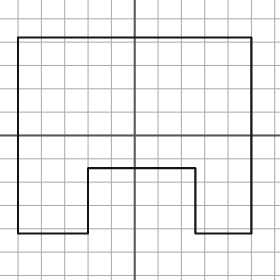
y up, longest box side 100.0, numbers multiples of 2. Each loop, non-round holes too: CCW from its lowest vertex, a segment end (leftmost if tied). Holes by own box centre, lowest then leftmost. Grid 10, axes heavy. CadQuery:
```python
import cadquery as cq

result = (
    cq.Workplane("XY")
    .moveTo(-50.0, -42.0)
    .lineTo(-20.0, -42.0)
    .lineTo(-20.0, -14.0)
    .lineTo(26.0, -14.0)
    .lineTo(26.0, -42.0)
    .lineTo(50.0, -42.0)
    .lineTo(50.0, 42.0)
    .lineTo(-50.0, 42.0)
    .close()
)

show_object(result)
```